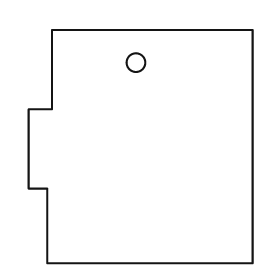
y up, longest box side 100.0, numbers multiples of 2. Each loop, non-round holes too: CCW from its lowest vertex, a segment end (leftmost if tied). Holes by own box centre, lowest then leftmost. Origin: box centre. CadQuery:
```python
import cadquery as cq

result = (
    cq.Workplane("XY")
    .moveTo(-40.0, -50.0)
    .lineTo(48.0, -50.0)
    .lineTo(48.0, 50.0)
    .lineTo(-38.0, 50.0)
    .lineTo(-38.0, 16.0)
    .lineTo(-48.0, 16.0)
    .lineTo(-48.0, -18.0)
    .lineTo(-40.0, -18.0)
    .close()
    .moveTo(-2.0, 36.0)
    .circle(4.0)
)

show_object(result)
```